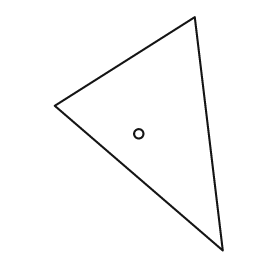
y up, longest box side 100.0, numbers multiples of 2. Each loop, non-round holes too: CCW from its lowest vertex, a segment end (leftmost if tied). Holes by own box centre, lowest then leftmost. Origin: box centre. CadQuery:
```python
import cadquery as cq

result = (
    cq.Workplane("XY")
    .moveTo(36.0, -50.0)
    .lineTo(24.0, 50.0)
    .lineTo(-36.0, 12.0)
    .close()
    .moveTo(0.0, 0.0)
    .circle(2.0)
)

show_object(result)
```